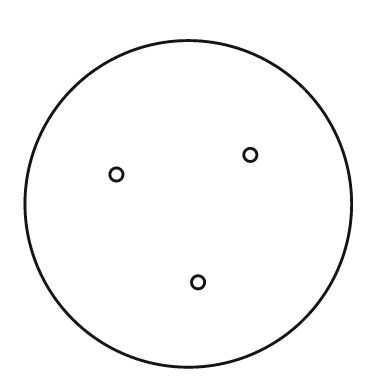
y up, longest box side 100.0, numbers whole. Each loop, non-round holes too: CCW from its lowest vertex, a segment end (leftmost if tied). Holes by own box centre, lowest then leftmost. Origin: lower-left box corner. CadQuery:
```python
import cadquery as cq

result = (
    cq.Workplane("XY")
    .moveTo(50.0, 50.0)
    .circle(50.0)
    .moveTo(53.0, 26.0)
    .circle(2.0)
    .moveTo(28.0, 59.0)
    .circle(2.0)
    .moveTo(69.0, 65.0)
    .circle(2.0)
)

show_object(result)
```